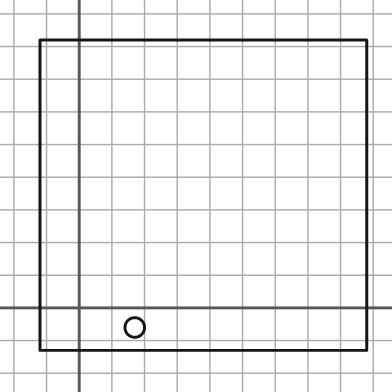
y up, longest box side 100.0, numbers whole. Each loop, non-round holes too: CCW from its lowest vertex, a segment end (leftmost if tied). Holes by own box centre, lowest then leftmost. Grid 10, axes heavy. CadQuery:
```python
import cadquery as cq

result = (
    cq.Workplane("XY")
    .moveTo(-12.0, -13.0)
    .lineTo(88.0, -13.0)
    .lineTo(88.0, 82.0)
    .lineTo(-12.0, 82.0)
    .close()
    .moveTo(17.0, -6.0)
    .circle(3.0)
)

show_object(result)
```